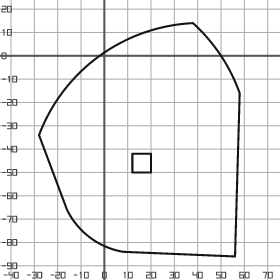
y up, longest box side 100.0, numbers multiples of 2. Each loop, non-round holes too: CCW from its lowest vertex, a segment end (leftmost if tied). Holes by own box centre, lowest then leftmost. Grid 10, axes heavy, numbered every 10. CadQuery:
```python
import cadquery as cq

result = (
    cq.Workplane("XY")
    .moveTo(56.0, -86.0)
    .lineTo(58.0, -16.0)
    .threePointArc((50.0, 0.0), (38.0, 14.0))
    .threePointArc((-2.0, 0.0), (-28.0, -34.0))
    .lineTo(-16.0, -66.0)
    .threePointArc((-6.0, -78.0), (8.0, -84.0))
    .close()
    .moveTo(12.0, -50.0)
    .lineTo(20.0, -50.0)
    .lineTo(20.0, -42.0)
    .lineTo(12.0, -42.0)
    .close()
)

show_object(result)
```